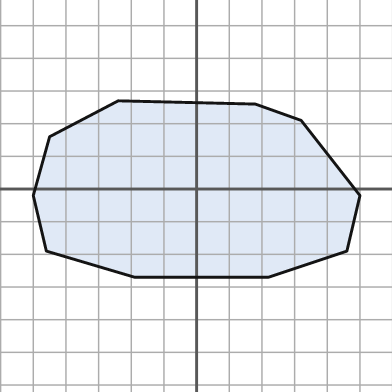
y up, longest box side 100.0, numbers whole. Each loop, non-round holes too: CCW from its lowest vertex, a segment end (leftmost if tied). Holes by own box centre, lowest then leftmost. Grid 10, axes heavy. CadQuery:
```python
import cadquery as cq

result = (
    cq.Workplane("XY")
    .moveTo(-19.0, -27.0)
    .lineTo(22.0, -27.0)
    .lineTo(46.0, -19.0)
    .lineTo(50.0, -2.0)
    .lineTo(32.0, 21.0)
    .lineTo(18.0, 26.0)
    .lineTo(-24.0, 27.0)
    .lineTo(-45.0, 16.0)
    .lineTo(-50.0, -2.0)
    .lineTo(-46.0, -19.0)
    .close()
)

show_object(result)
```